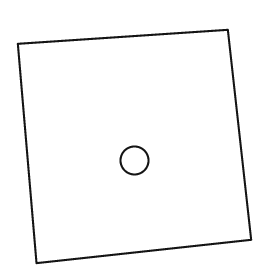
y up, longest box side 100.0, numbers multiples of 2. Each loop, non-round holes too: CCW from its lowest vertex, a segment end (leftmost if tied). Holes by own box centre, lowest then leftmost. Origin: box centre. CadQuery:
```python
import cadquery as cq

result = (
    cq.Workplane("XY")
    .moveTo(-42.0, -50.0)
    .lineTo(50.0, -40.0)
    .lineTo(40.0, 50.0)
    .lineTo(-50.0, 44.0)
    .close()
    .moveTo(0.0, -6.0)
    .circle(6.0)
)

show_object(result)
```